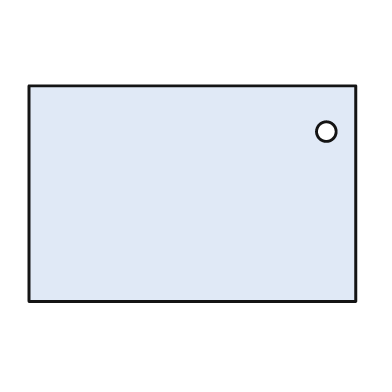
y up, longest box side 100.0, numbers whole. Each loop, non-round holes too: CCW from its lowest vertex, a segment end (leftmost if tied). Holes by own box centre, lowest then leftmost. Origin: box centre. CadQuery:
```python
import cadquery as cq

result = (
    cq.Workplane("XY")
    .moveTo(-50.0, -33.0)
    .lineTo(50.0, -33.0)
    .lineTo(50.0, 33.0)
    .lineTo(-50.0, 33.0)
    .close()
    .moveTo(41.0, 19.0)
    .circle(3.0)
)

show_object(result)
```